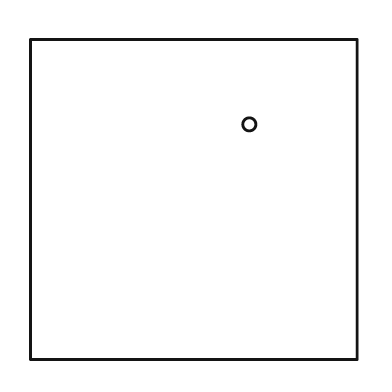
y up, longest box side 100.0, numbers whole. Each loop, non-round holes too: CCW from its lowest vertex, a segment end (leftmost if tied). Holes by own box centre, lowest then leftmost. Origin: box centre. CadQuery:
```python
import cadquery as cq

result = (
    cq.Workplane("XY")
    .moveTo(-50.0, -49.0)
    .lineTo(50.0, -49.0)
    .lineTo(50.0, 49.0)
    .lineTo(-50.0, 49.0)
    .close()
    .moveTo(17.0, 23.0)
    .circle(2.0)
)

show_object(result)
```